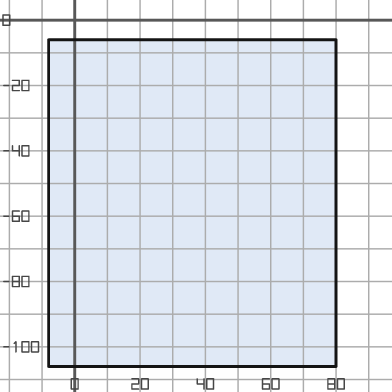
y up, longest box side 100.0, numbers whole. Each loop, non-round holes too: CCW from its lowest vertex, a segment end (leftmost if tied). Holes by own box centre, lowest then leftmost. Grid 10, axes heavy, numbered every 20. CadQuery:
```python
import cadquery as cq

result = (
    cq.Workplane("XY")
    .moveTo(-8.0, -106.0)
    .lineTo(80.0, -106.0)
    .lineTo(80.0, -6.0)
    .lineTo(-8.0, -6.0)
    .close()
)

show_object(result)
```